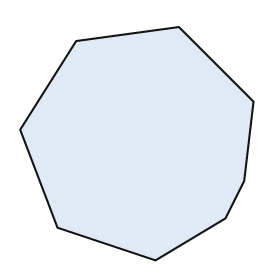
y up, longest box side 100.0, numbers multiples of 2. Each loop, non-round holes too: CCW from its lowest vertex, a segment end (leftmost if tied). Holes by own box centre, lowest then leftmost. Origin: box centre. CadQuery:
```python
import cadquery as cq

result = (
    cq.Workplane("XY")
    .moveTo(8.0, -50.0)
    .lineTo(38.0, -32.0)
    .lineTo(46.0, -16.0)
    .lineTo(50.0, 18.0)
    .lineTo(18.0, 50.0)
    .lineTo(-26.0, 44.0)
    .lineTo(-50.0, 6.0)
    .lineTo(-34.0, -36.0)
    .close()
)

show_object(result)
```